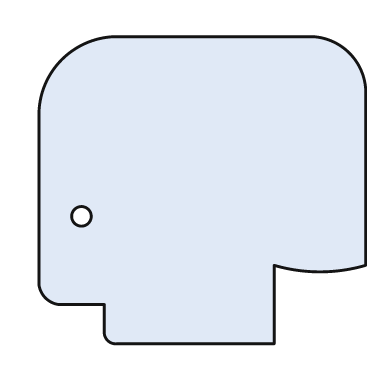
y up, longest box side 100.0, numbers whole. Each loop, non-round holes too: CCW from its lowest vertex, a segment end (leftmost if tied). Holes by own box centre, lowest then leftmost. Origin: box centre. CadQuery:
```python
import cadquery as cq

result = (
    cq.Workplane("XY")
    .moveTo(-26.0, -47.0)
    .lineTo(22.0, -47.0)
    .lineTo(22.0, -23.0)
    .threePointArc((36.0, -25.0), (50.0, -23.0))
    .lineTo(50.0, 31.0)
    .threePointArc((45.0, 42.0), (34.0, 47.0))
    .lineTo(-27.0, 47.0)
    .threePointArc((-43.0, 40.0), (-50.0, 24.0))
    .lineTo(-50.0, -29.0)
    .threePointArc((-48.0, -33.0), (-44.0, -35.0))
    .lineTo(-30.0, -35.0)
    .lineTo(-30.0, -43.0)
    .threePointArc((-29.0, -46.0), (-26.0, -47.0))
    .close()
    .moveTo(-37.0, -8.0)
    .circle(3.0)
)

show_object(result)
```